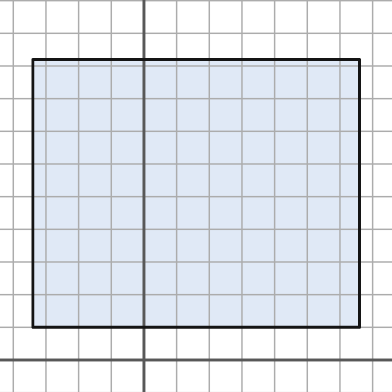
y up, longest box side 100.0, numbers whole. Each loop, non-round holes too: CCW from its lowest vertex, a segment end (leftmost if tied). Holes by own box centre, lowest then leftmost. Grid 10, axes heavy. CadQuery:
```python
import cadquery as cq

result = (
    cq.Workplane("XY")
    .moveTo(-34.0, 10.0)
    .lineTo(66.0, 10.0)
    .lineTo(66.0, 92.0)
    .lineTo(-34.0, 92.0)
    .close()
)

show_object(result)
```